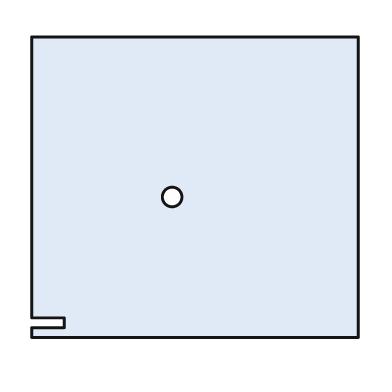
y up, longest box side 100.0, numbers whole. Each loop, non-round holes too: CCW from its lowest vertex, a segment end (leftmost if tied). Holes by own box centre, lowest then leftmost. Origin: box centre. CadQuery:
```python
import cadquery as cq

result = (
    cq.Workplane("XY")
    .moveTo(-50.0, -46.0)
    .lineTo(50.0, -46.0)
    .lineTo(50.0, 46.0)
    .lineTo(-50.0, 46.0)
    .lineTo(-50.0, -40.0)
    .lineTo(-40.0, -40.0)
    .lineTo(-40.0, -43.0)
    .lineTo(-50.0, -43.0)
    .close()
    .moveTo(-7.0, -3.0)
    .circle(3.0)
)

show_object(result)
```